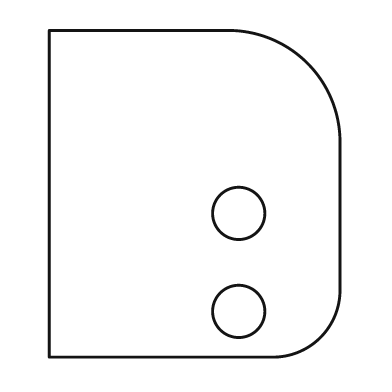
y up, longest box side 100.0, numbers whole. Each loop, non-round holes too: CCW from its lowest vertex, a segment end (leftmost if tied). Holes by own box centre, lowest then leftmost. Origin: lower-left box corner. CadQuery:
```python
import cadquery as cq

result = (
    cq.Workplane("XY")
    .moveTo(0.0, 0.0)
    .lineTo(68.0, 0.0)
    .threePointArc((83.0, 6.0), (89.0, 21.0))
    .lineTo(89.0, 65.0)
    .threePointArc((79.0, 90.0), (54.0, 100.0))
    .lineTo(0.0, 100.0)
    .close()
    .moveTo(58.0, 14.0)
    .circle(8.0)
    .moveTo(58.0, 44.0)
    .circle(8.0)
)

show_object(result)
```